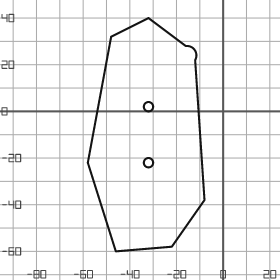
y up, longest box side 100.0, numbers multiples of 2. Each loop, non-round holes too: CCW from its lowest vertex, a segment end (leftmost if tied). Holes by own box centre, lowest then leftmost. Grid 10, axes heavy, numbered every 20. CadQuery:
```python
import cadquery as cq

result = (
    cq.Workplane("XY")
    .moveTo(-46.0, -60.0)
    .lineTo(-22.0, -58.0)
    .lineTo(-8.0, -38.0)
    .lineTo(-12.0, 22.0)
    .threePointArc((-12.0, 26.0), (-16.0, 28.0))
    .lineTo(-32.0, 40.0)
    .lineTo(-48.0, 32.0)
    .lineTo(-58.0, -22.0)
    .close()
    .moveTo(-32.0, -22.0)
    .circle(2.0)
    .moveTo(-32.0, 2.0)
    .circle(2.0)
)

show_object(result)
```